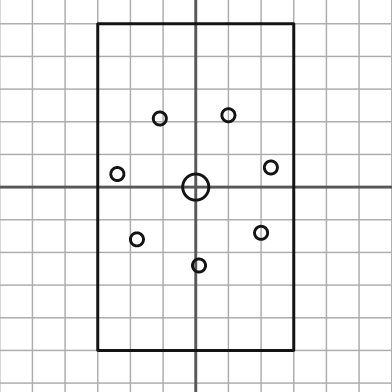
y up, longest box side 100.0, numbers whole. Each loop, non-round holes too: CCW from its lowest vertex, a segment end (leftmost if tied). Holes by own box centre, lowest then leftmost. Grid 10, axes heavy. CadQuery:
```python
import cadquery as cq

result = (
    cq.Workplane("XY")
    .moveTo(-30.0, -50.0)
    .lineTo(30.0, -50.0)
    .lineTo(30.0, 50.0)
    .lineTo(-30.0, 50.0)
    .close()
    .moveTo(1.0, -24.0)
    .circle(2.0)
    .moveTo(-18.0, -16.0)
    .circle(2.0)
    .moveTo(20.0, -14.0)
    .circle(2.0)
    .moveTo(0.0, 0.0)
    .circle(4.0)
    .moveTo(-24.0, 4.0)
    .circle(2.0)
    .moveTo(23.0, 6.0)
    .circle(2.0)
    .moveTo(-11.0, 21.0)
    .circle(2.0)
    .moveTo(10.0, 22.0)
    .circle(2.0)
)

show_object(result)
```